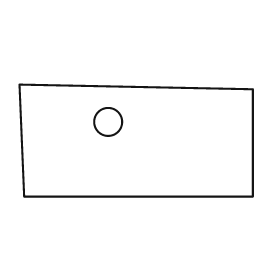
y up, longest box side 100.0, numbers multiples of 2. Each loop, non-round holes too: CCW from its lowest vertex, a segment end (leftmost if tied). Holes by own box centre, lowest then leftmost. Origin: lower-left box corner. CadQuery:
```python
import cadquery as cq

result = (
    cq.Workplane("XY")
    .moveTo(2.0, 0.0)
    .lineTo(100.0, 0.0)
    .lineTo(100.0, 46.0)
    .lineTo(0.0, 48.0)
    .close()
    .moveTo(38.0, 32.0)
    .circle(6.0)
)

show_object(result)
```